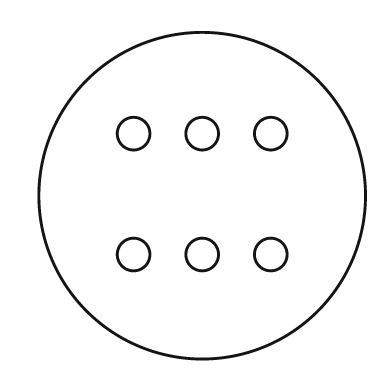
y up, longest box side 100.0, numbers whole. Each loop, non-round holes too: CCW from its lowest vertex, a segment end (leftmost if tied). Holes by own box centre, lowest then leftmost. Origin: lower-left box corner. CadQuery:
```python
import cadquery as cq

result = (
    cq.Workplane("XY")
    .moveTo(50.0, 50.0)
    .circle(50.0)
    .moveTo(29.0, 32.0)
    .circle(5.0)
    .moveTo(50.0, 32.0)
    .circle(5.0)
    .moveTo(71.0, 32.0)
    .circle(5.0)
    .moveTo(29.0, 69.0)
    .circle(5.0)
    .moveTo(50.0, 69.0)
    .circle(5.0)
    .moveTo(71.0, 69.0)
    .circle(5.0)
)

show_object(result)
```